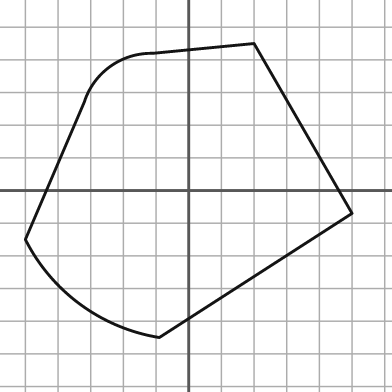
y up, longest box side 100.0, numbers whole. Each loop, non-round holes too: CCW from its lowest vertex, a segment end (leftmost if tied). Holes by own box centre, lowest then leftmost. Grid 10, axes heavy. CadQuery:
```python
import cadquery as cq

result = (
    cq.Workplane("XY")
    .moveTo(-9.0, -45.0)
    .lineTo(50.0, -7.0)
    .lineTo(20.0, 45.0)
    .lineTo(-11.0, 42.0)
    .threePointArc((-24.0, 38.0), (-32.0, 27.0))
    .lineTo(-50.0, -15.0)
    .threePointArc((-33.0, -35.0), (-9.0, -45.0))
    .close()
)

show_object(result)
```